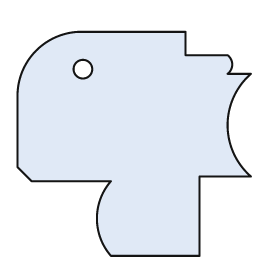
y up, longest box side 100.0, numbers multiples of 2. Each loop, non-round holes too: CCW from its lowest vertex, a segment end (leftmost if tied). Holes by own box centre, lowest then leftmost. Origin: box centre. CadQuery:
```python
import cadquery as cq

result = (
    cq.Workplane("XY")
    .moveTo(-10.0, -48.0)
    .lineTo(28.0, -48.0)
    .lineTo(28.0, -14.0)
    .lineTo(50.0, -14.0)
    .threePointArc((40.0, 8.0), (50.0, 30.0))
    .lineTo(40.0, 30.0)
    .threePointArc((42.0, 34.0), (40.0, 38.0))
    .lineTo(22.0, 38.0)
    .lineTo(22.0, 48.0)
    .lineTo(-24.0, 48.0)
    .threePointArc((-42.0, 40.0), (-50.0, 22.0))
    .lineTo(-50.0, -10.0)
    .lineTo(-44.0, -16.0)
    .lineTo(-10.0, -16.0)
    .threePointArc((-16.0, -32.0), (-10.0, -48.0))
    .close()
    .moveTo(-22.0, 32.0)
    .circle(4.0)
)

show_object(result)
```